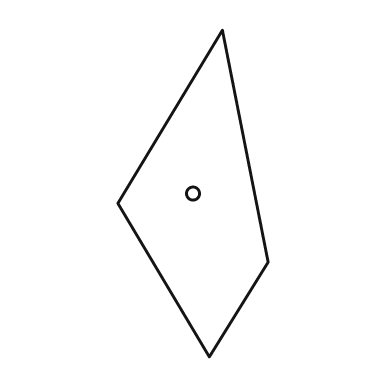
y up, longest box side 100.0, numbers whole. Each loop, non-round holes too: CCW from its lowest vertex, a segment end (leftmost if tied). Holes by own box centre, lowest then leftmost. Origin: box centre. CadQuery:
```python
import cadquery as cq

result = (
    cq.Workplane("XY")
    .moveTo(5.0, -50.0)
    .lineTo(23.0, -21.0)
    .lineTo(9.0, 50.0)
    .lineTo(-23.0, -3.0)
    .close()
    .moveTo(0.0, 0.0)
    .circle(2.0)
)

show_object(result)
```